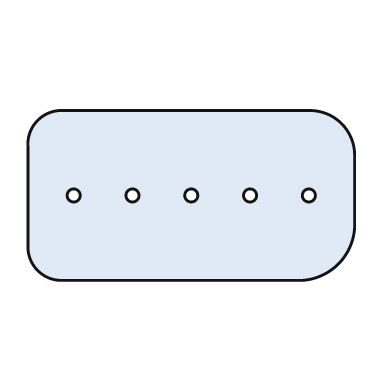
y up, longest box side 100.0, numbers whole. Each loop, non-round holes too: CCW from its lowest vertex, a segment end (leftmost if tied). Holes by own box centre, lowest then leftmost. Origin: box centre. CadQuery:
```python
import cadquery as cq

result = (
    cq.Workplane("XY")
    .moveTo(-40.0, -26.0)
    .lineTo(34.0, -26.0)
    .threePointArc((45.0, -21.0), (50.0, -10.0))
    .lineTo(50.0, 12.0)
    .threePointArc((46.0, 22.0), (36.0, 26.0))
    .lineTo(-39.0, 26.0)
    .threePointArc((-47.0, 23.0), (-50.0, 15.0))
    .lineTo(-50.0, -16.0)
    .threePointArc((-47.0, -23.0), (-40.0, -26.0))
    .close()
    .moveTo(-36.0, 0.0)
    .circle(2.0)
    .moveTo(-18.0, 0.0)
    .circle(2.0)
    .moveTo(0.0, 0.0)
    .circle(2.0)
    .moveTo(18.0, 0.0)
    .circle(2.0)
    .moveTo(36.0, 0.0)
    .circle(2.0)
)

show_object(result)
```